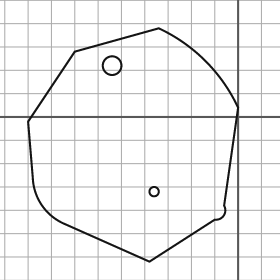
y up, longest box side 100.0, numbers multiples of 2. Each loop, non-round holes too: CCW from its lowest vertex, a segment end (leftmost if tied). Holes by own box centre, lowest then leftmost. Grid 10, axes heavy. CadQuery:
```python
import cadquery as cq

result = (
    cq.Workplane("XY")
    .moveTo(-38.0, -62.0)
    .lineTo(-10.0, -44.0)
    .threePointArc((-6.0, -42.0), (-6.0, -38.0))
    .lineTo(0.0, 4.0)
    .threePointArc((-14.0, 24.0), (-34.0, 38.0))
    .lineTo(-70.0, 28.0)
    .lineTo(-90.0, -2.0)
    .lineTo(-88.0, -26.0)
    .threePointArc((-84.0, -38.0), (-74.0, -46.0))
    .close()
    .moveTo(-36.0, -32.0)
    .circle(2.0)
    .moveTo(-54.0, 22.0)
    .circle(4.0)
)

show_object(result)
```